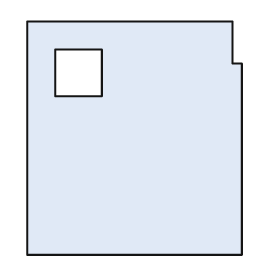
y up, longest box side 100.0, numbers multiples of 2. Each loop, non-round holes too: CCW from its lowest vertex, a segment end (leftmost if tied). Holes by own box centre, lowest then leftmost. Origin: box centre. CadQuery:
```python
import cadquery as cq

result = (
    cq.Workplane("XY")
    .moveTo(-46.0, -50.0)
    .lineTo(46.0, -50.0)
    .lineTo(46.0, 32.0)
    .lineTo(42.0, 32.0)
    .lineTo(42.0, 50.0)
    .lineTo(-46.0, 50.0)
    .close()
    .moveTo(-34.0, 18.0)
    .lineTo(-14.0, 18.0)
    .lineTo(-14.0, 38.0)
    .lineTo(-34.0, 38.0)
    .close()
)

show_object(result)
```